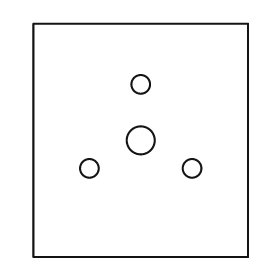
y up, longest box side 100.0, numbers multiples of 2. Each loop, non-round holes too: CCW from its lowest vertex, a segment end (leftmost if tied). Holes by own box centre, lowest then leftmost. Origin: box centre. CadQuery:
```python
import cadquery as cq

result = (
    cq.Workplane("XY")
    .moveTo(-46.0, -50.0)
    .lineTo(46.0, -50.0)
    .lineTo(46.0, 50.0)
    .lineTo(-46.0, 50.0)
    .close()
    .moveTo(-22.0, -12.0)
    .circle(4.0)
    .moveTo(22.0, -12.0)
    .circle(4.0)
    .moveTo(0.0, 0.0)
    .circle(6.0)
    .moveTo(0.0, 24.0)
    .circle(4.0)
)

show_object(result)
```